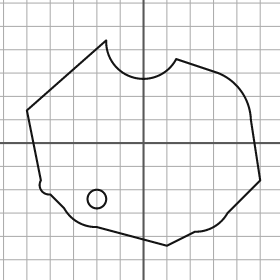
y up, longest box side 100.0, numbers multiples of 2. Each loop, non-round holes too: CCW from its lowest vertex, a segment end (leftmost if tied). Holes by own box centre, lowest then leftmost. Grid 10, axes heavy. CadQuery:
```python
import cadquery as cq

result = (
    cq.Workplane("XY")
    .moveTo(10.0, -44.0)
    .lineTo(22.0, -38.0)
    .threePointArc((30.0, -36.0), (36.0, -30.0))
    .lineTo(50.0, -16.0)
    .lineTo(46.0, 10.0)
    .threePointArc((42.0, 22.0), (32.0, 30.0))
    .lineTo(14.0, 36.0)
    .threePointArc((-4.0, 28.0), (-16.0, 44.0))
    .lineTo(-50.0, 14.0)
    .lineTo(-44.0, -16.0)
    .threePointArc((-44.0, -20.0), (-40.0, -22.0))
    .lineTo(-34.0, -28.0)
    .threePointArc((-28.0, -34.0), (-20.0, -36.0))
    .close()
    .moveTo(-20.0, -24.0)
    .circle(4.0)
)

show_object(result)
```